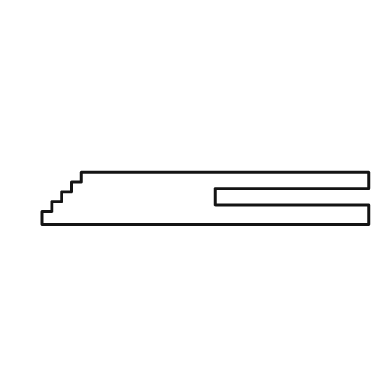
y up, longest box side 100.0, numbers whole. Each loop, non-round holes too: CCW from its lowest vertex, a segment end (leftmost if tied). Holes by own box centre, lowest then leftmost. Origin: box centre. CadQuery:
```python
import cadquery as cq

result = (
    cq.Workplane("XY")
    .moveTo(-50.0, -8.0)
    .lineTo(50.0, -8.0)
    .lineTo(50.0, -2.0)
    .lineTo(3.0, -2.0)
    .lineTo(3.0, 3.0)
    .lineTo(50.0, 3.0)
    .lineTo(50.0, 8.0)
    .lineTo(-38.0, 8.0)
    .lineTo(-38.0, 5.0)
    .lineTo(-41.0, 5.0)
    .lineTo(-41.0, 2.0)
    .lineTo(-44.0, 2.0)
    .lineTo(-44.0, -1.0)
    .lineTo(-47.0, -1.0)
    .lineTo(-47.0, -4.0)
    .lineTo(-50.0, -4.0)
    .close()
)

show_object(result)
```